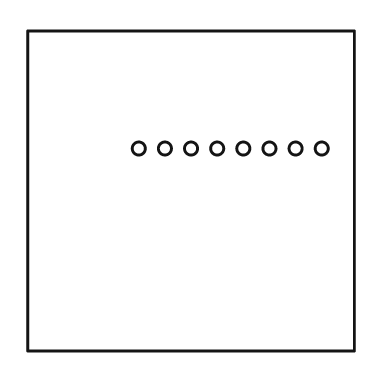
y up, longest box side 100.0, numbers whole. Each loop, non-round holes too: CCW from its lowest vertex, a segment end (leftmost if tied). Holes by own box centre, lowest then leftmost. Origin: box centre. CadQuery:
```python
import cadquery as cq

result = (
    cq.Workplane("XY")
    .moveTo(-50.0, -49.0)
    .lineTo(50.0, -49.0)
    .lineTo(50.0, 49.0)
    .lineTo(-50.0, 49.0)
    .close()
    .moveTo(-16.0, 13.0)
    .circle(2.0)
    .moveTo(-8.0, 13.0)
    .circle(2.0)
    .moveTo(0.0, 13.0)
    .circle(2.0)
    .moveTo(8.0, 13.0)
    .circle(2.0)
    .moveTo(16.0, 13.0)
    .circle(2.0)
    .moveTo(24.0, 13.0)
    .circle(2.0)
    .moveTo(32.0, 13.0)
    .circle(2.0)
    .moveTo(40.0, 13.0)
    .circle(2.0)
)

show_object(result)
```